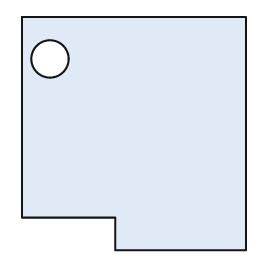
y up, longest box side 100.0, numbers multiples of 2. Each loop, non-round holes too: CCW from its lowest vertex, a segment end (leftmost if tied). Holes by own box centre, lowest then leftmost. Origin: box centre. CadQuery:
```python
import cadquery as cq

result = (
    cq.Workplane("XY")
    .moveTo(-8.0, -50.0)
    .lineTo(48.0, -50.0)
    .lineTo(48.0, 50.0)
    .lineTo(-48.0, 50.0)
    .lineTo(-48.0, -36.0)
    .lineTo(-8.0, -36.0)
    .close()
    .moveTo(-36.0, 32.0)
    .circle(8.0)
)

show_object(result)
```